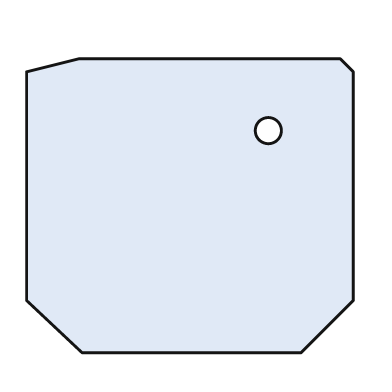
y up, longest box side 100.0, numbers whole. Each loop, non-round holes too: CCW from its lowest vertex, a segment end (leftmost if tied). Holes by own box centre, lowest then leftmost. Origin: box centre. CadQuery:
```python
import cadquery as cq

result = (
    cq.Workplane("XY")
    .moveTo(-33.0, -45.0)
    .lineTo(34.0, -45.0)
    .lineTo(50.0, -29.0)
    .lineTo(50.0, 41.0)
    .lineTo(46.0, 45.0)
    .lineTo(-34.0, 45.0)
    .lineTo(-50.0, 41.0)
    .lineTo(-50.0, -29.0)
    .close()
    .moveTo(24.0, 23.0)
    .circle(4.0)
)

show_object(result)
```